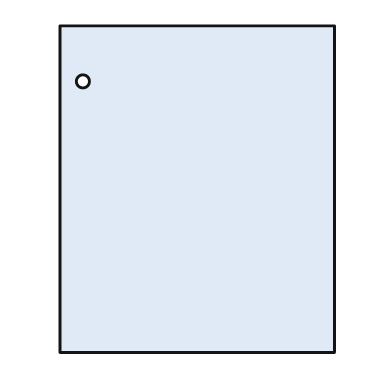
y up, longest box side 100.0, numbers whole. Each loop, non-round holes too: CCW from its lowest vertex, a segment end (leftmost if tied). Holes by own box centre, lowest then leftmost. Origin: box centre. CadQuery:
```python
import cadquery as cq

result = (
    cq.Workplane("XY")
    .moveTo(-42.0, -50.0)
    .lineTo(42.0, -50.0)
    .lineTo(42.0, 50.0)
    .lineTo(-42.0, 50.0)
    .close()
    .moveTo(-35.0, 33.0)
    .circle(2.0)
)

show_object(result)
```